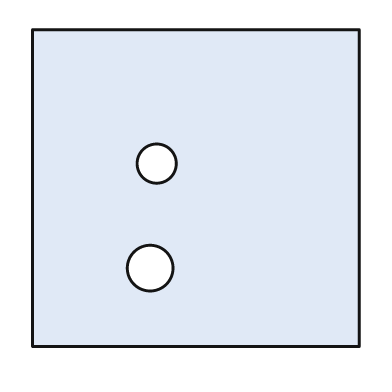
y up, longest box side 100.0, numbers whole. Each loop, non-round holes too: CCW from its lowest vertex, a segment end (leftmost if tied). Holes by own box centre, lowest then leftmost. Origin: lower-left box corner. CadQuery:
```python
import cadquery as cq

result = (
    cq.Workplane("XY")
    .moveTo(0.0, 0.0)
    .lineTo(100.0, 0.0)
    .lineTo(100.0, 97.0)
    .lineTo(0.0, 97.0)
    .close()
    .moveTo(36.0, 24.0)
    .circle(7.0)
    .moveTo(38.0, 56.0)
    .circle(6.0)
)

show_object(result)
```